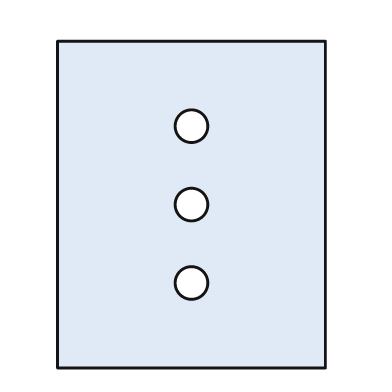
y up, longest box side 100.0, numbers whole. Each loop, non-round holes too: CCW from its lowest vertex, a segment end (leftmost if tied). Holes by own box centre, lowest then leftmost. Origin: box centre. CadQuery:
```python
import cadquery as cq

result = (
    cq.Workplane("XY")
    .moveTo(-41.0, -50.0)
    .lineTo(41.0, -50.0)
    .lineTo(41.0, 50.0)
    .lineTo(-41.0, 50.0)
    .close()
    .moveTo(0.0, -24.0)
    .circle(5.0)
    .moveTo(0.0, 0.0)
    .circle(5.0)
    .moveTo(0.0, 24.0)
    .circle(5.0)
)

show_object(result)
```